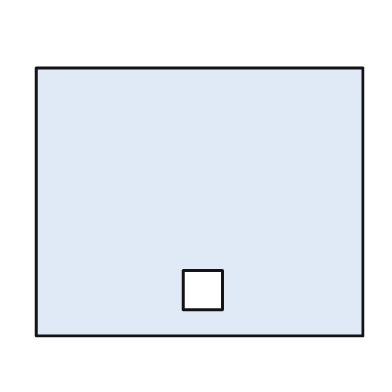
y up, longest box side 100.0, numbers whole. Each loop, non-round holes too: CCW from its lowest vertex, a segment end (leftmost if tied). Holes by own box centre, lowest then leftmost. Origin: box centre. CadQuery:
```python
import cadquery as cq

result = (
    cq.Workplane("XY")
    .moveTo(-50.0, -41.0)
    .lineTo(50.0, -41.0)
    .lineTo(50.0, 41.0)
    .lineTo(-50.0, 41.0)
    .close()
    .moveTo(-5.0, -33.0)
    .lineTo(7.0, -33.0)
    .lineTo(7.0, -21.0)
    .lineTo(-5.0, -21.0)
    .close()
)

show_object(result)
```